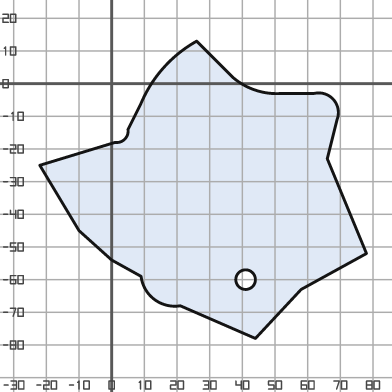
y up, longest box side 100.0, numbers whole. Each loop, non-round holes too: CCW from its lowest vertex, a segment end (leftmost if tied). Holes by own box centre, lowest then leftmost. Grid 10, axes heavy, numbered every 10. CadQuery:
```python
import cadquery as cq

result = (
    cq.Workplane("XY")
    .moveTo(44.0, -78.0)
    .lineTo(58.0, -63.0)
    .lineTo(78.0, -52.0)
    .lineTo(66.0, -23.0)
    .lineTo(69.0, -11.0)
    .threePointArc((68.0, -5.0), (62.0, -3.0))
    .lineTo(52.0, -3.0)
    .threePointArc((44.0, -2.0), (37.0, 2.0))
    .lineTo(26.0, 13.0)
    .threePointArc((16.0, 5.0), (9.0, -6.0))
    .lineTo(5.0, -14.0)
    .threePointArc((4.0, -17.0), (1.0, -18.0))
    .lineTo(-22.0, -25.0)
    .lineTo(-10.0, -45.0)
    .lineTo(0.0, -54.0)
    .lineTo(9.0, -59.0)
    .threePointArc((13.0, -66.0), (21.0, -68.0))
    .close()
    .moveTo(41.0, -60.0)
    .circle(3.0)
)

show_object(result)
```